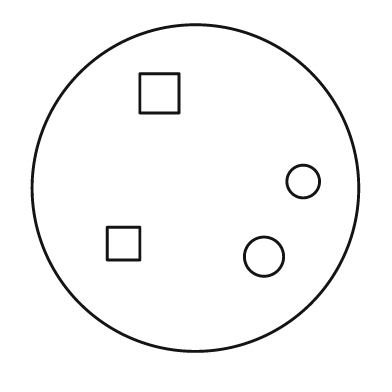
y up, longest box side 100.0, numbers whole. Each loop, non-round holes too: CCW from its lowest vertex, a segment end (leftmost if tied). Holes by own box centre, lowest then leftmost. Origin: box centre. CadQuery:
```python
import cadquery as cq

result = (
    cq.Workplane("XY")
    .moveTo(0.0, 0.0)
    .circle(50.0)
    .moveTo(21.0, -21.0)
    .circle(6.0)
    .moveTo(-27.0, -22.0)
    .lineTo(-17.0, -22.0)
    .lineTo(-17.0, -12.0)
    .lineTo(-27.0, -12.0)
    .close()
    .moveTo(33.0, 2.0)
    .circle(5.0)
    .moveTo(-17.0, 23.0)
    .lineTo(-5.0, 23.0)
    .lineTo(-5.0, 35.0)
    .lineTo(-17.0, 35.0)
    .close()
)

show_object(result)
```